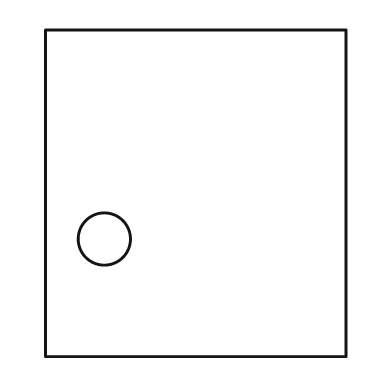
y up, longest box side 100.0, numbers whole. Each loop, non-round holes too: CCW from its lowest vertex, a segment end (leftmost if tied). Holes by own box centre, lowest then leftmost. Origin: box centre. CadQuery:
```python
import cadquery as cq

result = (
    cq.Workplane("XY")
    .moveTo(-46.0, -50.0)
    .lineTo(46.0, -50.0)
    .lineTo(46.0, 50.0)
    .lineTo(-46.0, 50.0)
    .close()
    .moveTo(-28.0, -14.0)
    .circle(8.0)
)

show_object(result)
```